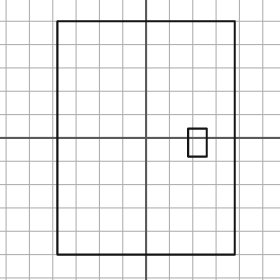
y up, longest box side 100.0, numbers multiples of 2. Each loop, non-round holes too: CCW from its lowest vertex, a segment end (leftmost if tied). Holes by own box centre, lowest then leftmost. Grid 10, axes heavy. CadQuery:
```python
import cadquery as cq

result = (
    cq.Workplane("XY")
    .moveTo(-38.0, -50.0)
    .lineTo(38.0, -50.0)
    .lineTo(38.0, 50.0)
    .lineTo(-38.0, 50.0)
    .close()
    .moveTo(18.0, -8.0)
    .lineTo(26.0, -8.0)
    .lineTo(26.0, 4.0)
    .lineTo(18.0, 4.0)
    .close()
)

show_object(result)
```